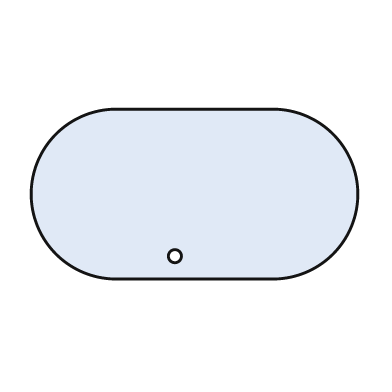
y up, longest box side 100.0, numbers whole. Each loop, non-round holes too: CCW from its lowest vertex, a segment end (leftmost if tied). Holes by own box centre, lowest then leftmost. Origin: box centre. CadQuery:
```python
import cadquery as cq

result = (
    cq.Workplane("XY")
    .moveTo(-24.0, -26.0)
    .lineTo(24.0, -26.0)
    .threePointArc((50.0, 0.0), (24.0, 26.0))
    .lineTo(-24.0, 26.0)
    .threePointArc((-50.0, 0.0), (-24.0, -26.0))
    .close()
    .moveTo(-6.0, -19.0)
    .circle(2.0)
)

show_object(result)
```